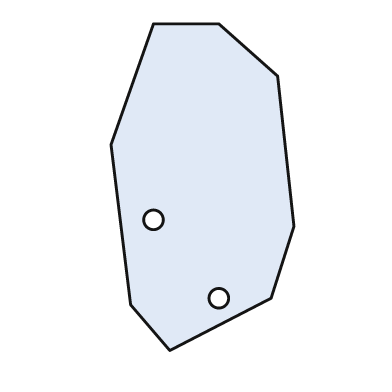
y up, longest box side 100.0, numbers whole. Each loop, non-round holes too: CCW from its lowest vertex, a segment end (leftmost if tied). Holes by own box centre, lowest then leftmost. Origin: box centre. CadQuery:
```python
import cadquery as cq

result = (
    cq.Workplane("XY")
    .moveTo(-10.0, -50.0)
    .lineTo(21.0, -34.0)
    .lineTo(28.0, -12.0)
    .lineTo(23.0, 34.0)
    .lineTo(5.0, 50.0)
    .lineTo(-15.0, 50.0)
    .lineTo(-28.0, 13.0)
    .lineTo(-22.0, -36.0)
    .close()
    .moveTo(5.0, -34.0)
    .circle(3.0)
    .moveTo(-15.0, -10.0)
    .circle(3.0)
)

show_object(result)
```